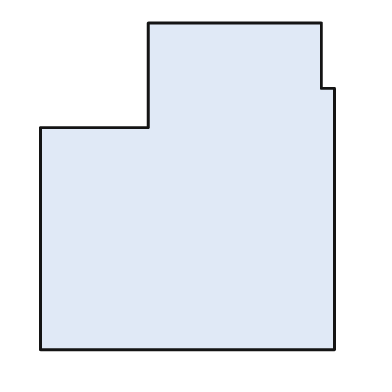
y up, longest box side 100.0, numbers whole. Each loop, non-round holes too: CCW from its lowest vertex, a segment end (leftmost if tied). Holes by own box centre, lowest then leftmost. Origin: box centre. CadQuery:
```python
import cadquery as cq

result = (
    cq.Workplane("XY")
    .moveTo(-45.0, -50.0)
    .lineTo(45.0, -50.0)
    .lineTo(45.0, 30.0)
    .lineTo(41.0, 30.0)
    .lineTo(41.0, 50.0)
    .lineTo(-12.0, 50.0)
    .lineTo(-12.0, 18.0)
    .lineTo(-45.0, 18.0)
    .close()
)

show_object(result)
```